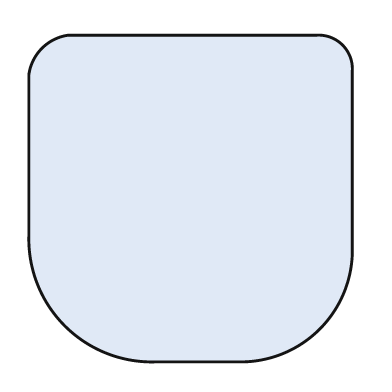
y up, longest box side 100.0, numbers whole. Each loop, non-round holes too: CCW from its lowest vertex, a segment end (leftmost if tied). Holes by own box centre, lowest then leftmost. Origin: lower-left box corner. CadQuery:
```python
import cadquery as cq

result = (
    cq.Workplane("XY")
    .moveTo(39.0, 0.0)
    .lineTo(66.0, 0.0)
    .threePointArc((89.0, 10.0), (99.0, 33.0))
    .lineTo(99.0, 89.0)
    .threePointArc((96.0, 97.0), (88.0, 100.0))
    .lineTo(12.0, 100.0)
    .threePointArc((4.0, 96.0), (0.0, 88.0))
    .lineTo(0.0, 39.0)
    .threePointArc((11.0, 11.0), (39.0, 0.0))
    .close()
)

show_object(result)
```